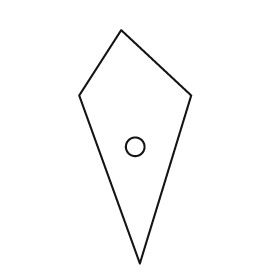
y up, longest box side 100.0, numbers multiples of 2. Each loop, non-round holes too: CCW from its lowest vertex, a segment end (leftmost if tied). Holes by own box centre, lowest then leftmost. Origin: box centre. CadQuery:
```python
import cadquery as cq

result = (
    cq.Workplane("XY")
    .moveTo(2.0, -50.0)
    .lineTo(24.0, 22.0)
    .lineTo(-6.0, 50.0)
    .lineTo(-24.0, 22.0)
    .close()
    .moveTo(0.0, 0.0)
    .circle(4.0)
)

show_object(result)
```